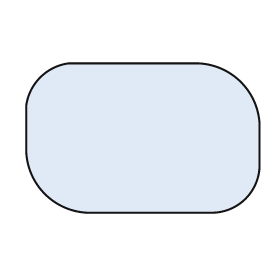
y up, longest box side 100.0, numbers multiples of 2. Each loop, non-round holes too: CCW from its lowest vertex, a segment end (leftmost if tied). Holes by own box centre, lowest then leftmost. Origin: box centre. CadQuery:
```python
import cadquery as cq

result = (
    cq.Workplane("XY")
    .moveTo(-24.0, -32.0)
    .lineTo(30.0, -32.0)
    .threePointArc((44.0, -26.0), (50.0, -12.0))
    .lineTo(50.0, 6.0)
    .threePointArc((42.0, 24.0), (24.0, 32.0))
    .lineTo(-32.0, 32.0)
    .threePointArc((-44.0, 26.0), (-50.0, 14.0))
    .lineTo(-50.0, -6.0)
    .threePointArc((-42.0, -24.0), (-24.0, -32.0))
    .close()
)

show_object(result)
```